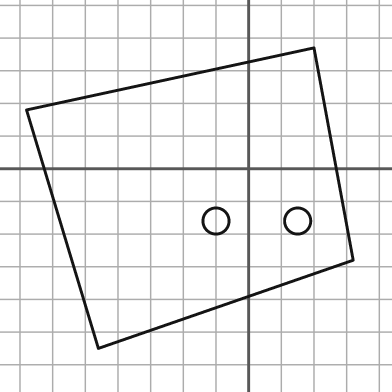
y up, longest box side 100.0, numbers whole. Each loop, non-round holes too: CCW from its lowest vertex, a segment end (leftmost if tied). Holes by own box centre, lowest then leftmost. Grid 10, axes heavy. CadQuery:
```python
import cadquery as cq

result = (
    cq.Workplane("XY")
    .moveTo(-46.0, -55.0)
    .lineTo(32.0, -28.0)
    .lineTo(20.0, 37.0)
    .lineTo(-68.0, 18.0)
    .close()
    .moveTo(-10.0, -16.0)
    .circle(4.0)
    .moveTo(15.0, -16.0)
    .circle(4.0)
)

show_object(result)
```